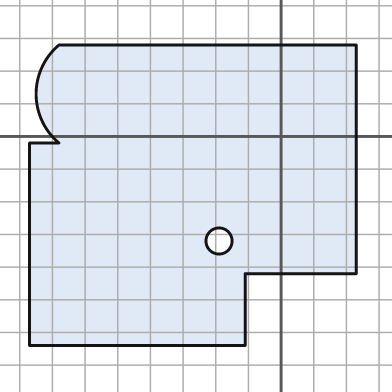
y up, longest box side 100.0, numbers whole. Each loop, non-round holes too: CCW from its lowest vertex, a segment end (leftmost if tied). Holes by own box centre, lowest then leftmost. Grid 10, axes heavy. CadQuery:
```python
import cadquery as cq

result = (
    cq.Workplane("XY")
    .moveTo(-77.0, -64.0)
    .lineTo(-11.0, -64.0)
    .lineTo(-11.0, -42.0)
    .lineTo(23.0, -42.0)
    .lineTo(23.0, 28.0)
    .lineTo(-68.0, 28.0)
    .threePointArc((-75.0, 13.0), (-68.0, -2.0))
    .lineTo(-77.0, -2.0)
    .close()
    .moveTo(-19.0, -32.0)
    .circle(4.0)
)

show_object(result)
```